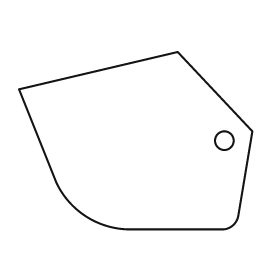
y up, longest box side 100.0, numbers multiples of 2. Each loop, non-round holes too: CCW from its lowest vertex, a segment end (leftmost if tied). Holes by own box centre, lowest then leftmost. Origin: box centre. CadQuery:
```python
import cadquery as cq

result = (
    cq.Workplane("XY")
    .moveTo(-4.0, -38.0)
    .lineTo(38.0, -38.0)
    .threePointArc((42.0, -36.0), (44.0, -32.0))
    .lineTo(50.0, 4.0)
    .lineTo(18.0, 38.0)
    .lineTo(-50.0, 22.0)
    .lineTo(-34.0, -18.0)
    .threePointArc((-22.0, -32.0), (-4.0, -38.0))
    .close()
    .moveTo(38.0, 0.0)
    .circle(4.0)
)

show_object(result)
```